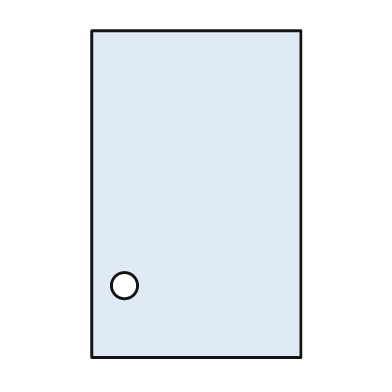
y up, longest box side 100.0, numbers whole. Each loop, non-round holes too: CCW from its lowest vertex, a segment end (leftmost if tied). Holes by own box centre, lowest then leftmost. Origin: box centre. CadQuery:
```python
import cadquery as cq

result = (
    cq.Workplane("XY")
    .moveTo(-32.0, -50.0)
    .lineTo(32.0, -50.0)
    .lineTo(32.0, 50.0)
    .lineTo(-32.0, 50.0)
    .close()
    .moveTo(-22.0, -28.0)
    .circle(4.0)
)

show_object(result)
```